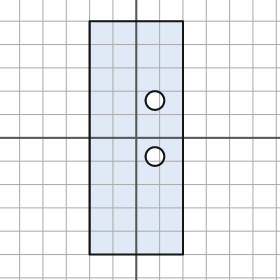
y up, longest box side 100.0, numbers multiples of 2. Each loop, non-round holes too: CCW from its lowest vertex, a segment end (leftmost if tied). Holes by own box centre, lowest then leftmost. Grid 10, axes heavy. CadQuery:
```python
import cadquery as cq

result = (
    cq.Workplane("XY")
    .moveTo(-20.0, -50.0)
    .lineTo(20.0, -50.0)
    .lineTo(20.0, 50.0)
    .lineTo(-20.0, 50.0)
    .close()
    .moveTo(8.0, -8.0)
    .circle(4.0)
    .moveTo(8.0, 16.0)
    .circle(4.0)
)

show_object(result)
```